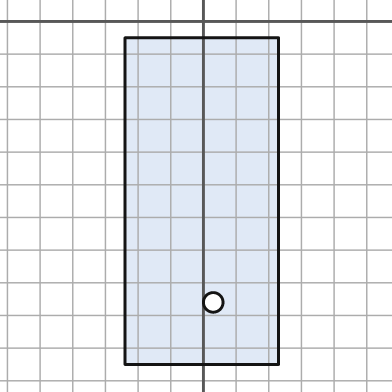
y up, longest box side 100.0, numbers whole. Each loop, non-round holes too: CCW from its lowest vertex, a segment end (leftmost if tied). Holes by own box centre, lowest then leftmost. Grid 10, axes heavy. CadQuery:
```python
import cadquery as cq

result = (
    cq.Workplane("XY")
    .moveTo(-24.0, -105.0)
    .lineTo(23.0, -105.0)
    .lineTo(23.0, -5.0)
    .lineTo(-24.0, -5.0)
    .close()
    .moveTo(3.0, -86.0)
    .circle(3.0)
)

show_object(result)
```